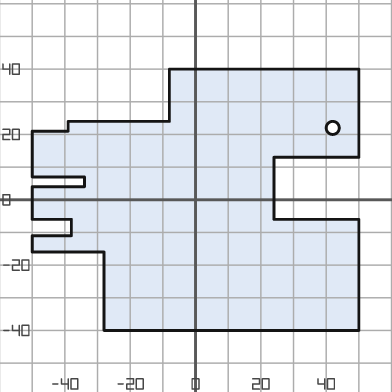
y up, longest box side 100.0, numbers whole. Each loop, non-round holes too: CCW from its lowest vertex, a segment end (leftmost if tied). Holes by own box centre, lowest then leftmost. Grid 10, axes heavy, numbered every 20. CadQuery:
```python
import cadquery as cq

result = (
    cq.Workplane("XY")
    .moveTo(-28.0, -40.0)
    .lineTo(50.0, -40.0)
    .lineTo(50.0, -6.0)
    .lineTo(24.0, -6.0)
    .lineTo(24.0, 13.0)
    .lineTo(50.0, 13.0)
    .lineTo(50.0, 40.0)
    .lineTo(-8.0, 40.0)
    .lineTo(-8.0, 24.0)
    .lineTo(-39.0, 24.0)
    .lineTo(-39.0, 21.0)
    .lineTo(-50.0, 21.0)
    .lineTo(-50.0, 7.0)
    .lineTo(-34.0, 7.0)
    .lineTo(-34.0, 4.0)
    .lineTo(-50.0, 4.0)
    .lineTo(-50.0, -6.0)
    .lineTo(-38.0, -6.0)
    .lineTo(-38.0, -11.0)
    .lineTo(-50.0, -11.0)
    .lineTo(-50.0, -16.0)
    .lineTo(-28.0, -16.0)
    .close()
    .moveTo(42.0, 22.0)
    .circle(2.0)
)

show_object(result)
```